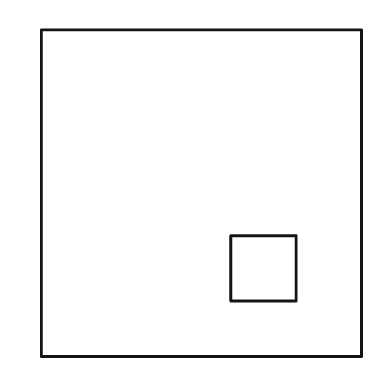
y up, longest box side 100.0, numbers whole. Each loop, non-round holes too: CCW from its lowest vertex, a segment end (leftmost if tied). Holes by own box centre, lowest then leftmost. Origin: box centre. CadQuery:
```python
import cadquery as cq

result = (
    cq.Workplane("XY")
    .moveTo(-49.0, -50.0)
    .lineTo(49.0, -50.0)
    .lineTo(49.0, 50.0)
    .lineTo(-49.0, 50.0)
    .close()
    .moveTo(9.0, -33.0)
    .lineTo(29.0, -33.0)
    .lineTo(29.0, -13.0)
    .lineTo(9.0, -13.0)
    .close()
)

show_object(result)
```